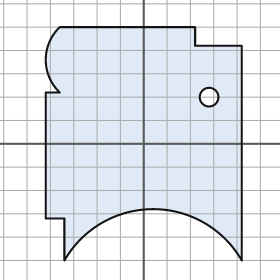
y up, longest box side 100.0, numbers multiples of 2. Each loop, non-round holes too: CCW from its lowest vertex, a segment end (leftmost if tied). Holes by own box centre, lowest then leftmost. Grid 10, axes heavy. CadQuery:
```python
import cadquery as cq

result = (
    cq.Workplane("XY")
    .moveTo(-34.0, -50.0)
    .threePointArc((4.0, -28.0), (42.0, -50.0))
    .lineTo(42.0, 42.0)
    .lineTo(22.0, 42.0)
    .lineTo(22.0, 50.0)
    .lineTo(-36.0, 50.0)
    .threePointArc((-42.0, 36.0), (-36.0, 22.0))
    .lineTo(-42.0, 22.0)
    .lineTo(-42.0, -32.0)
    .lineTo(-34.0, -32.0)
    .close()
    .moveTo(28.0, 20.0)
    .circle(4.0)
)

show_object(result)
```